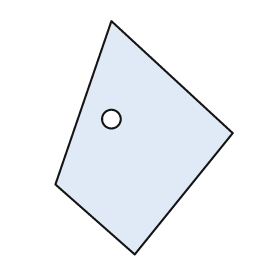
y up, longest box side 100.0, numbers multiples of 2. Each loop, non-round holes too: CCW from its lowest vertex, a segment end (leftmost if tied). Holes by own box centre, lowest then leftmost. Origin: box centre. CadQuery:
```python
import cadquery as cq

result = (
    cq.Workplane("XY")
    .moveTo(-4.0, -50.0)
    .lineTo(38.0, 2.0)
    .lineTo(-14.0, 50.0)
    .lineTo(-38.0, -20.0)
    .close()
    .moveTo(-14.0, 8.0)
    .circle(4.0)
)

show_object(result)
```